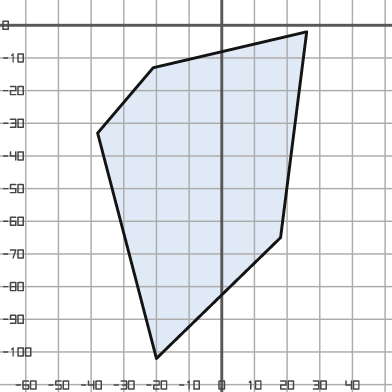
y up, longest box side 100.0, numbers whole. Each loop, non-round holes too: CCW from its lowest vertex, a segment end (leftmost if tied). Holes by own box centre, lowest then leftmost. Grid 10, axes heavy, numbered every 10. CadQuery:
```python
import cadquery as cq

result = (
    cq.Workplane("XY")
    .moveTo(-20.0, -102.0)
    .lineTo(18.0, -65.0)
    .lineTo(26.0, -2.0)
    .lineTo(-21.0, -13.0)
    .lineTo(-38.0, -33.0)
    .close()
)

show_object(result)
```